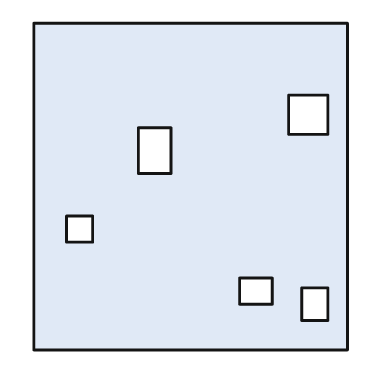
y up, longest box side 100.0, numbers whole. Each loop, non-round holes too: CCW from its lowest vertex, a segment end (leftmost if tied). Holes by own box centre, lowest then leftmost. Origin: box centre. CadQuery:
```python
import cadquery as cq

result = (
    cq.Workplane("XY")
    .moveTo(-48.0, -50.0)
    .lineTo(48.0, -50.0)
    .lineTo(48.0, 50.0)
    .lineTo(-48.0, 50.0)
    .close()
    .moveTo(34.0, -41.0)
    .lineTo(42.0, -41.0)
    .lineTo(42.0, -31.0)
    .lineTo(34.0, -31.0)
    .close()
    .moveTo(15.0, -36.0)
    .lineTo(25.0, -36.0)
    .lineTo(25.0, -28.0)
    .lineTo(15.0, -28.0)
    .close()
    .moveTo(-38.0, -17.0)
    .lineTo(-30.0, -17.0)
    .lineTo(-30.0, -9.0)
    .lineTo(-38.0, -9.0)
    .close()
    .moveTo(-16.0, 4.0)
    .lineTo(-6.0, 4.0)
    .lineTo(-6.0, 18.0)
    .lineTo(-16.0, 18.0)
    .close()
    .moveTo(30.0, 16.0)
    .lineTo(42.0, 16.0)
    .lineTo(42.0, 28.0)
    .lineTo(30.0, 28.0)
    .close()
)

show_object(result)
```